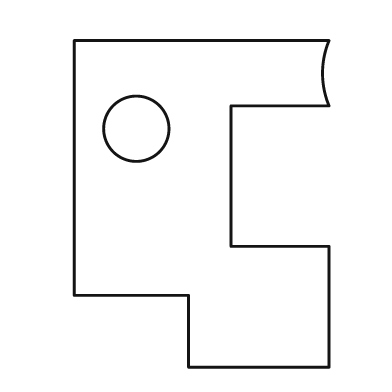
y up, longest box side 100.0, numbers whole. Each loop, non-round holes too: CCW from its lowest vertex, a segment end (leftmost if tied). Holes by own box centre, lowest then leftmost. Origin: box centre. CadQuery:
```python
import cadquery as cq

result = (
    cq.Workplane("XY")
    .moveTo(-4.0, -50.0)
    .lineTo(39.0, -50.0)
    .lineTo(39.0, -13.0)
    .lineTo(9.0, -13.0)
    .lineTo(9.0, 30.0)
    .lineTo(39.0, 30.0)
    .threePointArc((37.0, 40.0), (39.0, 50.0))
    .lineTo(-39.0, 50.0)
    .lineTo(-39.0, -28.0)
    .lineTo(-4.0, -28.0)
    .close()
    .moveTo(-20.0, 23.0)
    .circle(10.0)
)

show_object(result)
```